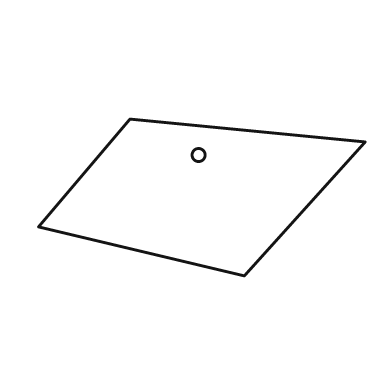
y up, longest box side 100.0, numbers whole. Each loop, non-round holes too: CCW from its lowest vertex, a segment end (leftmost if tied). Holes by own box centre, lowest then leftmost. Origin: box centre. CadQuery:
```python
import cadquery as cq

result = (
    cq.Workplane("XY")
    .moveTo(13.0, -24.0)
    .lineTo(50.0, 17.0)
    .lineTo(-22.0, 24.0)
    .lineTo(-50.0, -9.0)
    .close()
    .moveTo(-1.0, 13.0)
    .circle(2.0)
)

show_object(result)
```